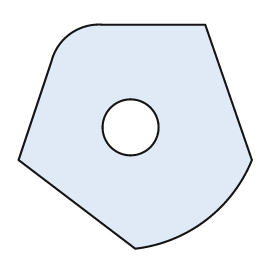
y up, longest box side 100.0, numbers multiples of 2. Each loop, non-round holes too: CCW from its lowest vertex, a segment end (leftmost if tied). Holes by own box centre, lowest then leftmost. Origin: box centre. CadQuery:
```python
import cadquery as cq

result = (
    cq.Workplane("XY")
    .moveTo(0.0, -48.0)
    .threePointArc((30.0, -36.0), (50.0, -10.0))
    .lineTo(30.0, 48.0)
    .lineTo(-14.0, 48.0)
    .threePointArc((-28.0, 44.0), (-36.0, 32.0))
    .lineTo(-50.0, -10.0)
    .close()
    .moveTo(-2.0, 4.0)
    .circle(12.0)
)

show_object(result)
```